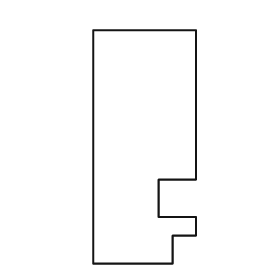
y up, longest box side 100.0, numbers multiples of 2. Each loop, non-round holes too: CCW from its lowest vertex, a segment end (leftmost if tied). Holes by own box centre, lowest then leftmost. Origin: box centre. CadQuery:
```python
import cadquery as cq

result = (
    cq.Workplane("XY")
    .moveTo(-22.0, -50.0)
    .lineTo(12.0, -50.0)
    .lineTo(12.0, -38.0)
    .lineTo(22.0, -38.0)
    .lineTo(22.0, -30.0)
    .lineTo(6.0, -30.0)
    .lineTo(6.0, -14.0)
    .lineTo(22.0, -14.0)
    .lineTo(22.0, 50.0)
    .lineTo(-22.0, 50.0)
    .close()
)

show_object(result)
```